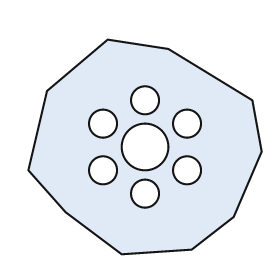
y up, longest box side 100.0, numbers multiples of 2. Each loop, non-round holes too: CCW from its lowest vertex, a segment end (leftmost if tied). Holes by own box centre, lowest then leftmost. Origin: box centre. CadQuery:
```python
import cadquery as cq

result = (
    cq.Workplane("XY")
    .moveTo(-10.0, -46.0)
    .lineTo(20.0, -44.0)
    .lineTo(38.0, -30.0)
    .lineTo(50.0, -2.0)
    .lineTo(46.0, 20.0)
    .lineTo(10.0, 42.0)
    .lineTo(-16.0, 46.0)
    .lineTo(-42.0, 24.0)
    .lineTo(-50.0, -10.0)
    .lineTo(-34.0, -28.0)
    .close()
    .moveTo(0.0, -20.0)
    .circle(6.0)
    .moveTo(-18.0, -10.0)
    .circle(6.0)
    .moveTo(18.0, -10.0)
    .circle(6.0)
    .moveTo(0.0, 0.0)
    .circle(10.0)
    .moveTo(-18.0, 10.0)
    .circle(6.0)
    .moveTo(18.0, 10.0)
    .circle(6.0)
    .moveTo(0.0, 20.0)
    .circle(6.0)
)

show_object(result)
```